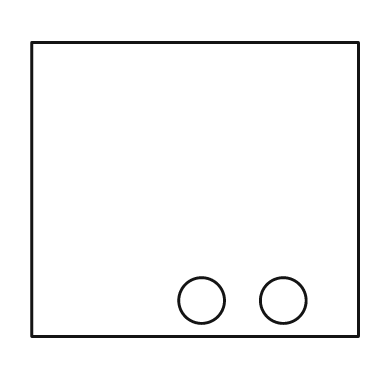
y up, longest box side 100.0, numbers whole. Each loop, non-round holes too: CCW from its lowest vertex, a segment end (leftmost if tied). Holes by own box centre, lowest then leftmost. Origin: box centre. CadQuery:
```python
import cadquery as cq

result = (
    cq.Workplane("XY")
    .moveTo(-50.0, -45.0)
    .lineTo(50.0, -45.0)
    .lineTo(50.0, 45.0)
    .lineTo(-50.0, 45.0)
    .close()
    .moveTo(2.0, -34.0)
    .circle(7.0)
    .moveTo(27.0, -34.0)
    .circle(7.0)
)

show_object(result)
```